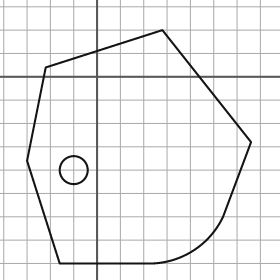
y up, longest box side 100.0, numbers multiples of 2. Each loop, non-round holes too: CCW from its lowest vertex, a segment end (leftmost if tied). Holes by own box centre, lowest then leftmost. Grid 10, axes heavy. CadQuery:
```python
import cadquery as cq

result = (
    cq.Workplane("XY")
    .moveTo(-16.0, -80.0)
    .lineTo(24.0, -80.0)
    .threePointArc((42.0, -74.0), (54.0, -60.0))
    .lineTo(66.0, -28.0)
    .lineTo(28.0, 20.0)
    .lineTo(-22.0, 4.0)
    .lineTo(-30.0, -36.0)
    .close()
    .moveTo(-10.0, -40.0)
    .circle(6.0)
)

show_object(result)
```